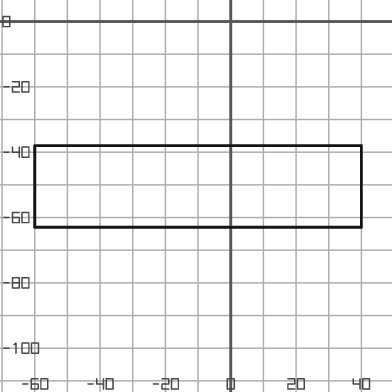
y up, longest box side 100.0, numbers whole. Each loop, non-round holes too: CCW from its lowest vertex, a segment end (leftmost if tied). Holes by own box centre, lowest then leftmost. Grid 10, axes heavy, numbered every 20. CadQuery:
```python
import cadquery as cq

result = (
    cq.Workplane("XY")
    .moveTo(-60.0, -63.0)
    .lineTo(40.0, -63.0)
    .lineTo(40.0, -38.0)
    .lineTo(-60.0, -38.0)
    .close()
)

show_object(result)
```